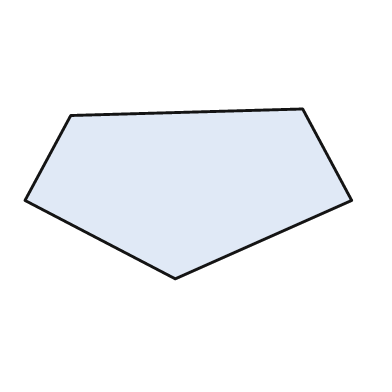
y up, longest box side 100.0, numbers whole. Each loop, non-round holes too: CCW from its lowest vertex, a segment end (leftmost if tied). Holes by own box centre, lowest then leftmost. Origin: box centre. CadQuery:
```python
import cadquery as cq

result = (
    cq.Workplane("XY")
    .moveTo(-4.0, -26.0)
    .lineTo(50.0, -2.0)
    .lineTo(35.0, 26.0)
    .lineTo(-36.0, 24.0)
    .lineTo(-50.0, -2.0)
    .close()
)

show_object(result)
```